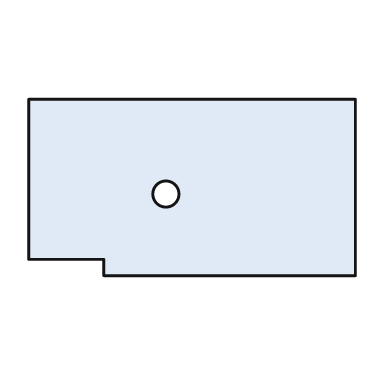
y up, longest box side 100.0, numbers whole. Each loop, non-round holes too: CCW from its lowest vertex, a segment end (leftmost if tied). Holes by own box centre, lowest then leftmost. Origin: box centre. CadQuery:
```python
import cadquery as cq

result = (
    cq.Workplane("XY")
    .moveTo(-27.0, -27.0)
    .lineTo(50.0, -27.0)
    .lineTo(50.0, 27.0)
    .lineTo(-50.0, 27.0)
    .lineTo(-50.0, -22.0)
    .lineTo(-27.0, -22.0)
    .close()
    .moveTo(-8.0, -2.0)
    .circle(4.0)
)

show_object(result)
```